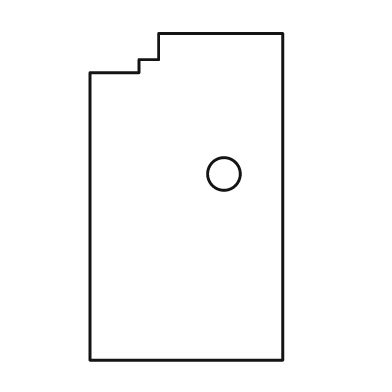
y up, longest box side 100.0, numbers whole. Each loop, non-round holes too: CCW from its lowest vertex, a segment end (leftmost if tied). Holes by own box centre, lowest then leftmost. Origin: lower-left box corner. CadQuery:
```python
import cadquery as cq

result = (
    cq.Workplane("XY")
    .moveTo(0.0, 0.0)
    .lineTo(59.0, 0.0)
    .lineTo(59.0, 100.0)
    .lineTo(21.0, 100.0)
    .lineTo(21.0, 92.0)
    .lineTo(15.0, 92.0)
    .lineTo(15.0, 88.0)
    .lineTo(0.0, 88.0)
    .close()
    .moveTo(41.0, 57.0)
    .circle(5.0)
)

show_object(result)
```